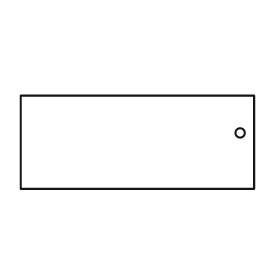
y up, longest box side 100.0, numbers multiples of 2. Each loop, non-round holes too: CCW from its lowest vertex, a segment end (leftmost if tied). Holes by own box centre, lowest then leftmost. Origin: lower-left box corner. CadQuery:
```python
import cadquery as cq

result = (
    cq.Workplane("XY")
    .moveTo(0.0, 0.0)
    .lineTo(100.0, 0.0)
    .lineTo(100.0, 40.0)
    .lineTo(0.0, 40.0)
    .close()
    .moveTo(94.0, 24.0)
    .circle(2.0)
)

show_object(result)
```